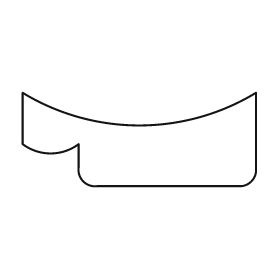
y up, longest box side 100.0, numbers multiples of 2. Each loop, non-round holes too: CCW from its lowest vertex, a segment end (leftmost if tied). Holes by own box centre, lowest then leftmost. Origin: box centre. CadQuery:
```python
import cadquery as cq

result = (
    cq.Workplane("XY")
    .moveTo(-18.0, -20.0)
    .lineTo(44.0, -20.0)
    .threePointArc((48.0, -18.0), (50.0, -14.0))
    .lineTo(50.0, 20.0)
    .threePointArc((0.0, 6.0), (-50.0, 20.0))
    .lineTo(-50.0, -2.0)
    .threePointArc((-38.0, -6.0), (-26.0, -2.0))
    .lineTo(-26.0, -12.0)
    .threePointArc((-24.0, -18.0), (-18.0, -20.0))
    .close()
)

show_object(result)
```